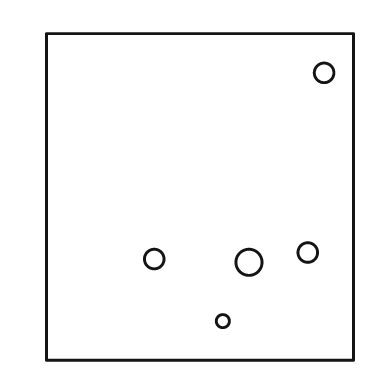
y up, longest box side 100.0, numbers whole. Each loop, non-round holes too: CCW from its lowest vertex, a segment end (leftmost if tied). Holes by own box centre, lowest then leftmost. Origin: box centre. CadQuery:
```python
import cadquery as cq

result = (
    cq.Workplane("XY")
    .moveTo(-47.0, -50.0)
    .lineTo(47.0, -50.0)
    .lineTo(47.0, 50.0)
    .lineTo(-47.0, 50.0)
    .close()
    .moveTo(7.0, -38.0)
    .circle(2.0)
    .moveTo(15.0, -20.0)
    .circle(4.0)
    .moveTo(-14.0, -19.0)
    .circle(3.0)
    .moveTo(33.0, -17.0)
    .circle(3.0)
    .moveTo(38.0, 38.0)
    .circle(3.0)
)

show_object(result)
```